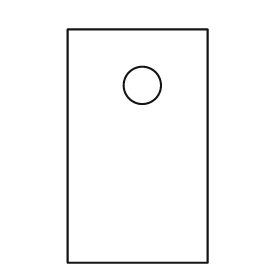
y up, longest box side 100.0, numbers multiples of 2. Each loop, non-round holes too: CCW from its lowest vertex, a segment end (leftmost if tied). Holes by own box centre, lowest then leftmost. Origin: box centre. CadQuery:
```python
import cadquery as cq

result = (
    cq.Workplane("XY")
    .moveTo(-30.0, -50.0)
    .lineTo(30.0, -50.0)
    .lineTo(30.0, 50.0)
    .lineTo(-30.0, 50.0)
    .close()
    .moveTo(2.0, 26.0)
    .circle(8.0)
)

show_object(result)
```